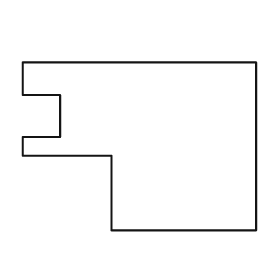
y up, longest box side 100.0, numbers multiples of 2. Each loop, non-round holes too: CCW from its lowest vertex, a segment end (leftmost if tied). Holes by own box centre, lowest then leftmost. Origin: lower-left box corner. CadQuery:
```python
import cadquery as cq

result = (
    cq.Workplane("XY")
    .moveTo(38.0, 0.0)
    .lineTo(100.0, 0.0)
    .lineTo(100.0, 72.0)
    .lineTo(0.0, 72.0)
    .lineTo(0.0, 58.0)
    .lineTo(16.0, 58.0)
    .lineTo(16.0, 40.0)
    .lineTo(0.0, 40.0)
    .lineTo(0.0, 32.0)
    .lineTo(38.0, 32.0)
    .close()
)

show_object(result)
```